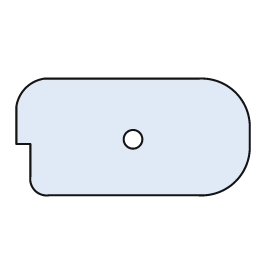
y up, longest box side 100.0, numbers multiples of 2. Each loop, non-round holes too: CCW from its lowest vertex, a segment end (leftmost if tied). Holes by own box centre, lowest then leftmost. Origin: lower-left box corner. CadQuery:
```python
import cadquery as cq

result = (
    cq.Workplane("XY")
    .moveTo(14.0, 0.0)
    .lineTo(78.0, 0.0)
    .threePointArc((94.0, 6.0), (100.0, 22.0))
    .lineTo(100.0, 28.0)
    .threePointArc((94.0, 44.0), (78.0, 50.0))
    .lineTo(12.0, 50.0)
    .threePointArc((4.0, 46.0), (0.0, 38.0))
    .lineTo(0.0, 22.0)
    .lineTo(6.0, 22.0)
    .lineTo(6.0, 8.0)
    .threePointArc((8.0, 2.0), (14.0, 0.0))
    .close()
    .moveTo(50.0, 24.0)
    .circle(4.0)
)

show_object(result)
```